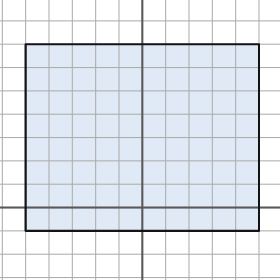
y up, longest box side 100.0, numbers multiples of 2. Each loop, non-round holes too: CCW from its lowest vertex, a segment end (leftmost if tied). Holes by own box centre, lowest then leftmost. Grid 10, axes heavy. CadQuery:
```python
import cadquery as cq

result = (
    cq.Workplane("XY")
    .moveTo(-50.0, -10.0)
    .lineTo(50.0, -10.0)
    .lineTo(50.0, 70.0)
    .lineTo(-50.0, 70.0)
    .close()
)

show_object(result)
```